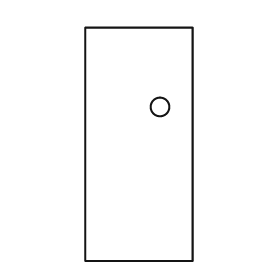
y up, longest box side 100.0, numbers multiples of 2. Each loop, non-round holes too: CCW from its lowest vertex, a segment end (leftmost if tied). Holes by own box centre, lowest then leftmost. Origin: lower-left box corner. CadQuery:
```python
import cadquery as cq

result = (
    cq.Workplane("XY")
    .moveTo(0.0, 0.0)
    .lineTo(46.0, 0.0)
    .lineTo(46.0, 100.0)
    .lineTo(0.0, 100.0)
    .close()
    .moveTo(32.0, 66.0)
    .circle(4.0)
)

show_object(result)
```